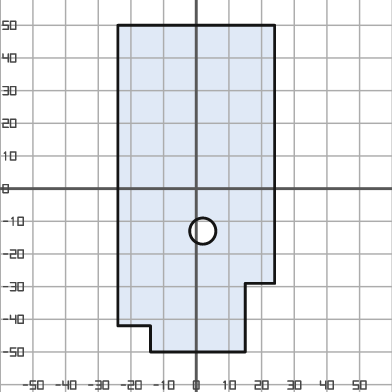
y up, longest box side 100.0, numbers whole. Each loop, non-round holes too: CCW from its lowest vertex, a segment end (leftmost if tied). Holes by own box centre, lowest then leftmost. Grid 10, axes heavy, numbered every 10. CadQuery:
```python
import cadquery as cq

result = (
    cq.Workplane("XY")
    .moveTo(-14.0, -50.0)
    .lineTo(15.0, -50.0)
    .lineTo(15.0, -29.0)
    .lineTo(24.0, -29.0)
    .lineTo(24.0, 50.0)
    .lineTo(-24.0, 50.0)
    .lineTo(-24.0, -42.0)
    .lineTo(-14.0, -42.0)
    .close()
    .moveTo(2.0, -13.0)
    .circle(4.0)
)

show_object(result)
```